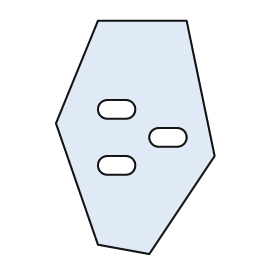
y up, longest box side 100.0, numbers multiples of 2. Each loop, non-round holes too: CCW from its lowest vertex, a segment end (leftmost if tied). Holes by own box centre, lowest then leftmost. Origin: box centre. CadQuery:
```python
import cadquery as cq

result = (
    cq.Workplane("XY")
    .moveTo(6.0, -50.0)
    .lineTo(34.0, -8.0)
    .lineTo(22.0, 50.0)
    .lineTo(-16.0, 50.0)
    .lineTo(-34.0, 6.0)
    .lineTo(-16.0, -46.0)
    .close()
    .moveTo(-12.0, -16.0)
    .lineTo(-4.0, -16.0)
    .threePointArc((0.0, -12.0), (-4.0, -8.0))
    .lineTo(-12.0, -8.0)
    .threePointArc((-16.0, -12.0), (-12.0, -16.0))
    .close()
    .moveTo(10.0, -4.0)
    .lineTo(18.0, -4.0)
    .threePointArc((22.0, 0.0), (18.0, 4.0))
    .lineTo(10.0, 4.0)
    .threePointArc((6.0, 0.0), (10.0, -4.0))
    .close()
    .moveTo(-12.0, 8.0)
    .lineTo(-4.0, 8.0)
    .threePointArc((0.0, 12.0), (-4.0, 16.0))
    .lineTo(-12.0, 16.0)
    .threePointArc((-16.0, 12.0), (-12.0, 8.0))
    .close()
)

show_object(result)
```